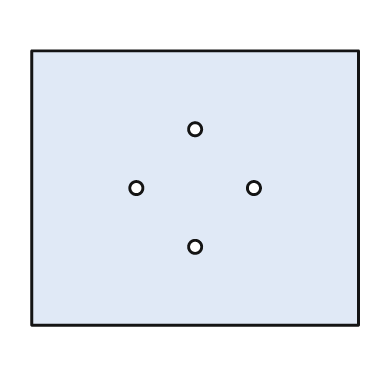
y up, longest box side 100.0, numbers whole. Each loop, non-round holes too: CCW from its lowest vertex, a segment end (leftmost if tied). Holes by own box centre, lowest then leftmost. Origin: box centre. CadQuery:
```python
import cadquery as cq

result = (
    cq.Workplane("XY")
    .moveTo(-50.0, -42.0)
    .lineTo(50.0, -42.0)
    .lineTo(50.0, 42.0)
    .lineTo(-50.0, 42.0)
    .close()
    .moveTo(0.0, -18.0)
    .circle(2.0)
    .moveTo(-18.0, 0.0)
    .circle(2.0)
    .moveTo(18.0, 0.0)
    .circle(2.0)
    .moveTo(0.0, 18.0)
    .circle(2.0)
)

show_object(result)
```